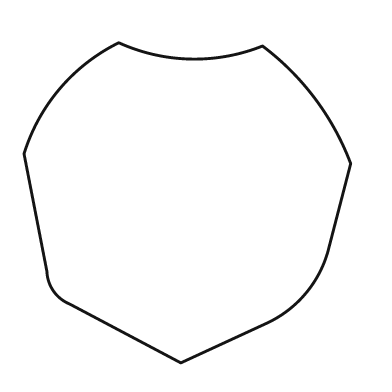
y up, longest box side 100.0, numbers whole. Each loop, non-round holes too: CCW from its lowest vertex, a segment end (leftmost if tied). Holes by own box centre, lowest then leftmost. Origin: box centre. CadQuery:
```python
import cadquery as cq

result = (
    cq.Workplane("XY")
    .moveTo(-2.0, -49.0)
    .lineTo(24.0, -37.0)
    .threePointArc((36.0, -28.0), (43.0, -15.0))
    .lineTo(50.0, 12.0)
    .threePointArc((39.0, 32.0), (23.0, 48.0))
    .threePointArc((1.0, 44.0), (-21.0, 49.0))
    .threePointArc((-39.0, 35.0), (-50.0, 15.0))
    .lineTo(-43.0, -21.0)
    .threePointArc((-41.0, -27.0), (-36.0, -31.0))
    .close()
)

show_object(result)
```